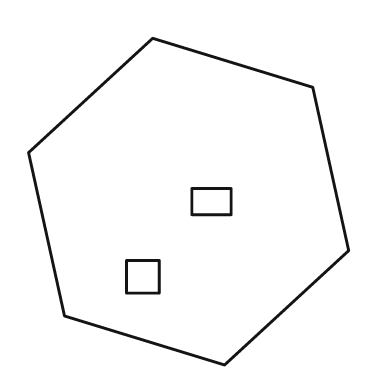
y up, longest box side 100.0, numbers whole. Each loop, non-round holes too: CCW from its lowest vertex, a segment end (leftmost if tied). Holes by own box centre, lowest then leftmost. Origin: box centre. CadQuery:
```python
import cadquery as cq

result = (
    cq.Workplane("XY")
    .moveTo(11.0, -50.0)
    .lineTo(49.0, -15.0)
    .lineTo(38.0, 35.0)
    .lineTo(-11.0, 50.0)
    .lineTo(-49.0, 15.0)
    .lineTo(-38.0, -35.0)
    .close()
    .moveTo(-19.0, -28.0)
    .lineTo(-9.0, -28.0)
    .lineTo(-9.0, -18.0)
    .lineTo(-19.0, -18.0)
    .close()
    .moveTo(1.0, -4.0)
    .lineTo(13.0, -4.0)
    .lineTo(13.0, 4.0)
    .lineTo(1.0, 4.0)
    .close()
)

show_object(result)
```